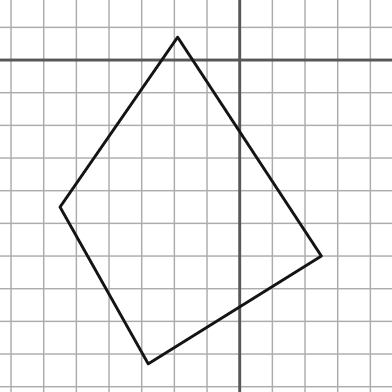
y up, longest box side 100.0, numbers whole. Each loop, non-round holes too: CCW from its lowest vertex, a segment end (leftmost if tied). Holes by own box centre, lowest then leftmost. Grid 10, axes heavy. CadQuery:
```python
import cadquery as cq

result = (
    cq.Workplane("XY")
    .moveTo(-28.0, -93.0)
    .lineTo(25.0, -60.0)
    .lineTo(-19.0, 7.0)
    .lineTo(-55.0, -45.0)
    .close()
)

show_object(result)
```